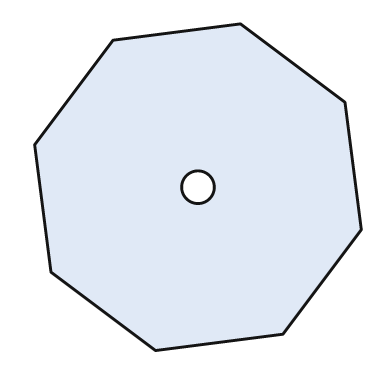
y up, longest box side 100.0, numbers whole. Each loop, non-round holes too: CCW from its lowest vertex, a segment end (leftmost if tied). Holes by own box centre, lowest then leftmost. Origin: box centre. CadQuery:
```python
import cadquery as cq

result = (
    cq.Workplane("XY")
    .moveTo(-13.0, -50.0)
    .lineTo(26.0, -45.0)
    .lineTo(50.0, -13.0)
    .lineTo(45.0, 26.0)
    .lineTo(13.0, 50.0)
    .lineTo(-26.0, 45.0)
    .lineTo(-50.0, 13.0)
    .lineTo(-45.0, -26.0)
    .close()
    .moveTo(0.0, 0.0)
    .circle(5.0)
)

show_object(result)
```